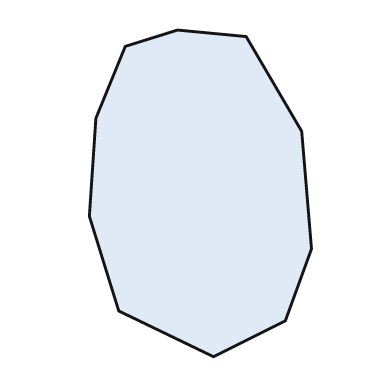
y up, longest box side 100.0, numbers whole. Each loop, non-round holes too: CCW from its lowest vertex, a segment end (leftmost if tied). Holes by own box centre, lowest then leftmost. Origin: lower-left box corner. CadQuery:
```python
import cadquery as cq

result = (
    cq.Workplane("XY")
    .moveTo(38.0, 0.0)
    .lineTo(60.0, 11.0)
    .lineTo(68.0, 33.0)
    .lineTo(65.0, 69.0)
    .lineTo(48.0, 98.0)
    .lineTo(27.0, 100.0)
    .lineTo(11.0, 95.0)
    .lineTo(2.0, 73.0)
    .lineTo(0.0, 43.0)
    .lineTo(9.0, 14.0)
    .close()
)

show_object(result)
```